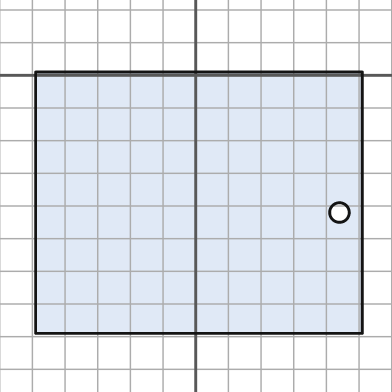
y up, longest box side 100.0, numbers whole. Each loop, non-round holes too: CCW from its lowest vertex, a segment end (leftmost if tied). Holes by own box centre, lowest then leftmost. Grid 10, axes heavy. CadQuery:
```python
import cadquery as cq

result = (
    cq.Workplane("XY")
    .moveTo(-49.0, -79.0)
    .lineTo(51.0, -79.0)
    .lineTo(51.0, 1.0)
    .lineTo(-49.0, 1.0)
    .close()
    .moveTo(44.0, -42.0)
    .circle(3.0)
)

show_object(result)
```